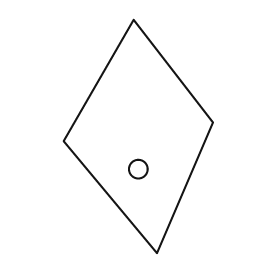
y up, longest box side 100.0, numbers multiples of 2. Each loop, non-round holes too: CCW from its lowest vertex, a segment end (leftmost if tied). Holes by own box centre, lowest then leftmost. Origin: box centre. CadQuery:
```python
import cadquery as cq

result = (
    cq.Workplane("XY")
    .moveTo(8.0, -50.0)
    .lineTo(32.0, 6.0)
    .lineTo(-2.0, 50.0)
    .lineTo(-32.0, -2.0)
    .close()
    .moveTo(0.0, -14.0)
    .circle(4.0)
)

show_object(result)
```